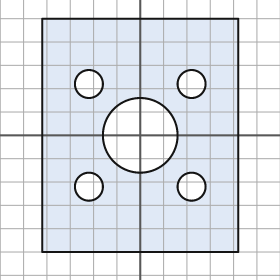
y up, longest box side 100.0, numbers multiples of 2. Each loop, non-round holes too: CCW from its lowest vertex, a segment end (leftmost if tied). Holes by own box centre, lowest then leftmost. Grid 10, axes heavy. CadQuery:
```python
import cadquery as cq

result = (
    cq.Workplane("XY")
    .moveTo(-42.0, -50.0)
    .lineTo(42.0, -50.0)
    .lineTo(42.0, 50.0)
    .lineTo(-42.0, 50.0)
    .close()
    .moveTo(-22.0, -22.0)
    .circle(6.0)
    .moveTo(22.0, -22.0)
    .circle(6.0)
    .moveTo(0.0, 0.0)
    .circle(16.0)
    .moveTo(-22.0, 22.0)
    .circle(6.0)
    .moveTo(22.0, 22.0)
    .circle(6.0)
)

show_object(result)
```